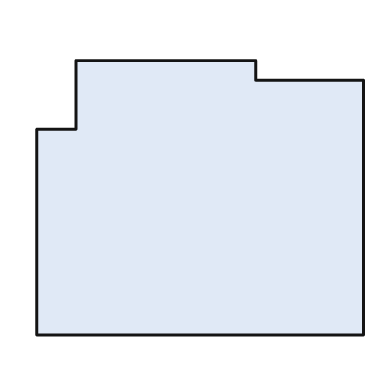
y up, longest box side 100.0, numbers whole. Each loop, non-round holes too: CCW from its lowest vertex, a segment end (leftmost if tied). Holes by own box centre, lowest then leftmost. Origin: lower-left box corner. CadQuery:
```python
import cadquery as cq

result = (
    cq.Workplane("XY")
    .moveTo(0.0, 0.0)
    .lineTo(100.0, 0.0)
    .lineTo(100.0, 78.0)
    .lineTo(67.0, 78.0)
    .lineTo(67.0, 84.0)
    .lineTo(12.0, 84.0)
    .lineTo(12.0, 63.0)
    .lineTo(0.0, 63.0)
    .close()
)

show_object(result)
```